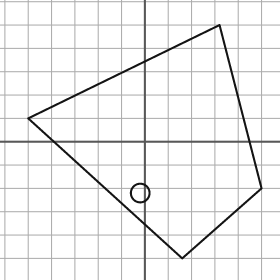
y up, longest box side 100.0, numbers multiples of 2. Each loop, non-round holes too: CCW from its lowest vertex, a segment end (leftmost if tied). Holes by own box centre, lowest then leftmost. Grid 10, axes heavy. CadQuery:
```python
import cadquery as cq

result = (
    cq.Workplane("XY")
    .moveTo(16.0, -50.0)
    .lineTo(50.0, -20.0)
    .lineTo(32.0, 50.0)
    .lineTo(-50.0, 10.0)
    .close()
    .moveTo(-2.0, -22.0)
    .circle(4.0)
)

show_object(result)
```